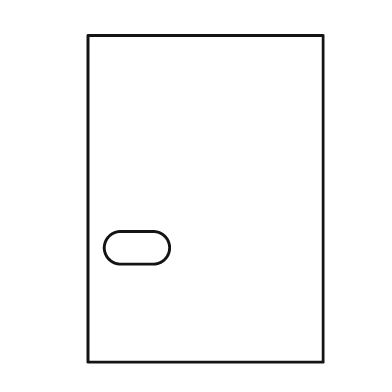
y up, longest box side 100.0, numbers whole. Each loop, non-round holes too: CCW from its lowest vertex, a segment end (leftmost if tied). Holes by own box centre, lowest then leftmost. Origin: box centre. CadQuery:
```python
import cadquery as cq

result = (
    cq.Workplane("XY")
    .moveTo(-36.0, -50.0)
    .lineTo(36.0, -50.0)
    .lineTo(36.0, 50.0)
    .lineTo(-36.0, 50.0)
    .close()
    .moveTo(-26.0, -20.0)
    .lineTo(-16.0, -20.0)
    .threePointArc((-11.0, -15.0), (-16.0, -10.0))
    .lineTo(-26.0, -10.0)
    .threePointArc((-31.0, -15.0), (-26.0, -20.0))
    .close()
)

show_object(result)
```